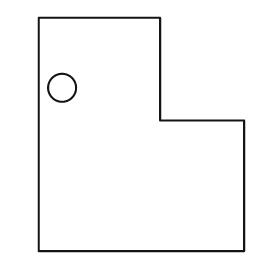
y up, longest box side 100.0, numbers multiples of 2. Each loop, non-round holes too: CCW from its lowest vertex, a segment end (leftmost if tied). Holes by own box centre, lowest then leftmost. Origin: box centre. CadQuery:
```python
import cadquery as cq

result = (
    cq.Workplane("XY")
    .moveTo(-44.0, -50.0)
    .lineTo(44.0, -50.0)
    .lineTo(44.0, 6.0)
    .lineTo(8.0, 6.0)
    .lineTo(8.0, 50.0)
    .lineTo(-44.0, 50.0)
    .close()
    .moveTo(-34.0, 20.0)
    .circle(6.0)
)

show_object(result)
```